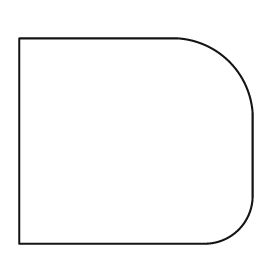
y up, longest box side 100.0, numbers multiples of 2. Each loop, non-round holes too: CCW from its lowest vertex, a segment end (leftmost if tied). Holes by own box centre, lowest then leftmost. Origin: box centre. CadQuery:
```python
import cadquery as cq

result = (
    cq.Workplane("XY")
    .moveTo(-50.0, -44.0)
    .lineTo(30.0, -44.0)
    .threePointArc((44.0, -38.0), (50.0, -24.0))
    .lineTo(50.0, 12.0)
    .threePointArc((40.0, 34.0), (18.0, 44.0))
    .lineTo(-50.0, 44.0)
    .close()
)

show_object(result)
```